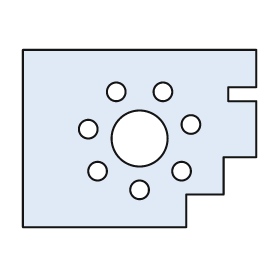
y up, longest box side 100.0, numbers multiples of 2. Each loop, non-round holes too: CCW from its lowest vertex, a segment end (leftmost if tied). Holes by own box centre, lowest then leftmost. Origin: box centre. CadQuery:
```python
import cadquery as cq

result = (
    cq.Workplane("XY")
    .moveTo(-50.0, -38.0)
    .lineTo(20.0, -38.0)
    .lineTo(20.0, -24.0)
    .lineTo(36.0, -24.0)
    .lineTo(36.0, -8.0)
    .lineTo(50.0, -8.0)
    .lineTo(50.0, 16.0)
    .lineTo(38.0, 16.0)
    .lineTo(38.0, 22.0)
    .lineTo(50.0, 22.0)
    .lineTo(50.0, 38.0)
    .lineTo(-50.0, 38.0)
    .close()
    .moveTo(0.0, -22.0)
    .circle(4.0)
    .moveTo(-18.0, -14.0)
    .circle(4.0)
    .moveTo(18.0, -14.0)
    .circle(4.0)
    .moveTo(0.0, 0.0)
    .circle(12.0)
    .moveTo(-22.0, 4.0)
    .circle(4.0)
    .moveTo(22.0, 6.0)
    .circle(4.0)
    .moveTo(-10.0, 20.0)
    .circle(4.0)
    .moveTo(10.0, 20.0)
    .circle(4.0)
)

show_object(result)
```